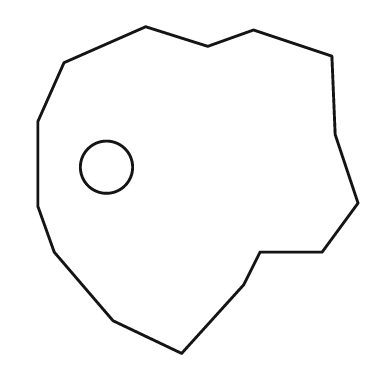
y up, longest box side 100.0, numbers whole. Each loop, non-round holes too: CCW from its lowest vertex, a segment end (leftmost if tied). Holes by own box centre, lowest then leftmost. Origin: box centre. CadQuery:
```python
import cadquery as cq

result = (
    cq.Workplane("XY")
    .moveTo(-5.0, -50.0)
    .lineTo(14.0, -29.0)
    .lineTo(19.0, -19.0)
    .lineTo(38.0, -19.0)
    .lineTo(49.0, -4.0)
    .lineTo(42.0, 17.0)
    .lineTo(41.0, 41.0)
    .lineTo(17.0, 49.0)
    .lineTo(3.0, 44.0)
    .lineTo(-16.0, 50.0)
    .lineTo(-41.0, 39.0)
    .lineTo(-49.0, 21.0)
    .lineTo(-49.0, -5.0)
    .lineTo(-44.0, -19.0)
    .lineTo(-26.0, -40.0)
    .close()
    .moveTo(-28.0, 7.0)
    .circle(8.0)
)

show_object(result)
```